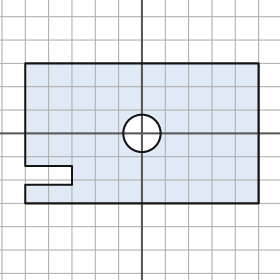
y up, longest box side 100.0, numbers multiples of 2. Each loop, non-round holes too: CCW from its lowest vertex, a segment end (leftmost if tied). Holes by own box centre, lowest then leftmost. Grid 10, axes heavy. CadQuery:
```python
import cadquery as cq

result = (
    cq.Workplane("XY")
    .moveTo(-50.0, -30.0)
    .lineTo(50.0, -30.0)
    .lineTo(50.0, 30.0)
    .lineTo(-50.0, 30.0)
    .lineTo(-50.0, -14.0)
    .lineTo(-30.0, -14.0)
    .lineTo(-30.0, -22.0)
    .lineTo(-50.0, -22.0)
    .close()
    .moveTo(0.0, 0.0)
    .circle(8.0)
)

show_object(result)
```